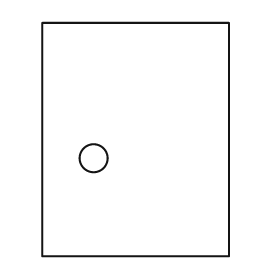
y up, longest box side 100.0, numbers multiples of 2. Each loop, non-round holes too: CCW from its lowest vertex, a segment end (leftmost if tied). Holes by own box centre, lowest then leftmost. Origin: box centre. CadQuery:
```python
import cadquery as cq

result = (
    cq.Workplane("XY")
    .moveTo(-40.0, -50.0)
    .lineTo(40.0, -50.0)
    .lineTo(40.0, 50.0)
    .lineTo(-40.0, 50.0)
    .close()
    .moveTo(-18.0, -8.0)
    .circle(6.0)
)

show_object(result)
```